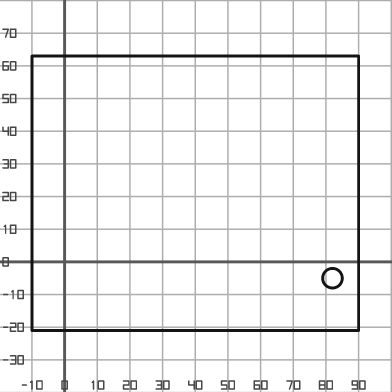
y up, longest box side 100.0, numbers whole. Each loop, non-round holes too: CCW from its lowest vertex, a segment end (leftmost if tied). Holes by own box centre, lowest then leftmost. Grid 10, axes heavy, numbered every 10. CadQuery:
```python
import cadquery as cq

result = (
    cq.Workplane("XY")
    .moveTo(-10.0, -21.0)
    .lineTo(90.0, -21.0)
    .lineTo(90.0, 63.0)
    .lineTo(-10.0, 63.0)
    .close()
    .moveTo(82.0, -5.0)
    .circle(3.0)
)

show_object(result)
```